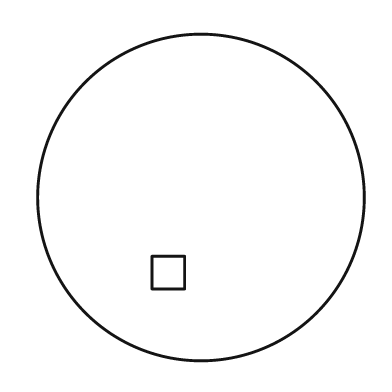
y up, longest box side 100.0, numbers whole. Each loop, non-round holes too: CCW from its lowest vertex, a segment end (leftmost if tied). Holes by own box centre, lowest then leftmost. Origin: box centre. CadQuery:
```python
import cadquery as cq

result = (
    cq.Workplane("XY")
    .moveTo(0.0, 0.0)
    .circle(50.0)
    .moveTo(-15.0, -28.0)
    .lineTo(-5.0, -28.0)
    .lineTo(-5.0, -18.0)
    .lineTo(-15.0, -18.0)
    .close()
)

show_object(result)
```